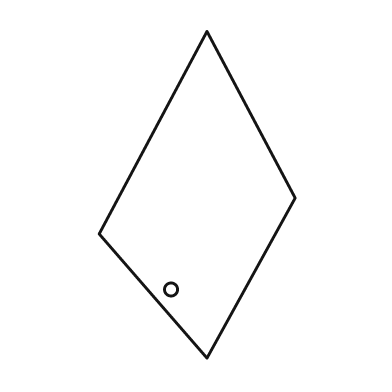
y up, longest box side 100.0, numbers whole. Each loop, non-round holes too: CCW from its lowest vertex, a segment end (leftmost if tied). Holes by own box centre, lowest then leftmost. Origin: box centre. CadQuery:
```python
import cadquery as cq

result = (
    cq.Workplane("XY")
    .moveTo(3.0, -50.0)
    .lineTo(30.0, -1.0)
    .lineTo(3.0, 50.0)
    .lineTo(-30.0, -12.0)
    .close()
    .moveTo(-8.0, -29.0)
    .circle(2.0)
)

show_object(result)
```